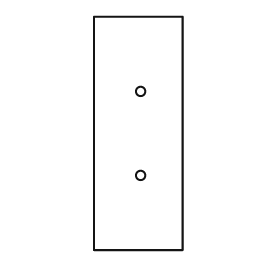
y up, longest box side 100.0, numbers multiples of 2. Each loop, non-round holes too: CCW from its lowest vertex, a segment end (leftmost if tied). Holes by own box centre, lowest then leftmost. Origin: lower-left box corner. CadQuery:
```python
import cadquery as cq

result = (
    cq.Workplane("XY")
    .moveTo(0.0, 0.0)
    .lineTo(38.0, 0.0)
    .lineTo(38.0, 100.0)
    .lineTo(0.0, 100.0)
    .close()
    .moveTo(20.0, 32.0)
    .circle(2.0)
    .moveTo(20.0, 68.0)
    .circle(2.0)
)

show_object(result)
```